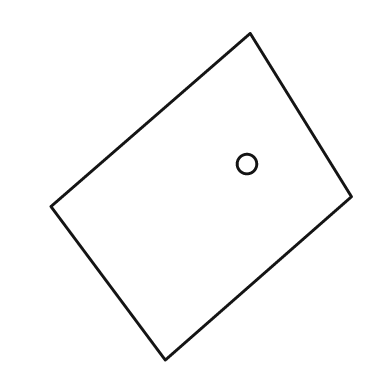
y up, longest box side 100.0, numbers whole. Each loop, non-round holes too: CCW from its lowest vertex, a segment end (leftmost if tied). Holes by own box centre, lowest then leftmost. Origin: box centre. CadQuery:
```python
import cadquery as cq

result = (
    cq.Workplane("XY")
    .moveTo(-11.0, -50.0)
    .lineTo(46.0, 0.0)
    .lineTo(15.0, 50.0)
    .lineTo(-46.0, -3.0)
    .close()
    .moveTo(14.0, 10.0)
    .circle(3.0)
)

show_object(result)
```